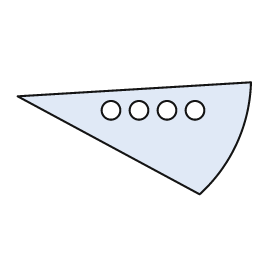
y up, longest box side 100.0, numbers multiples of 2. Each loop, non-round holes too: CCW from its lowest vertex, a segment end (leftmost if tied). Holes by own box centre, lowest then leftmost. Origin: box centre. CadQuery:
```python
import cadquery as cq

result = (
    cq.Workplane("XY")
    .moveTo(28.0, -24.0)
    .threePointArc((44.0, -2.0), (50.0, 24.0))
    .lineTo(-50.0, 18.0)
    .close()
    .moveTo(-10.0, 12.0)
    .circle(4.0)
    .moveTo(2.0, 12.0)
    .circle(4.0)
    .moveTo(14.0, 12.0)
    .circle(4.0)
    .moveTo(26.0, 12.0)
    .circle(4.0)
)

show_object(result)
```